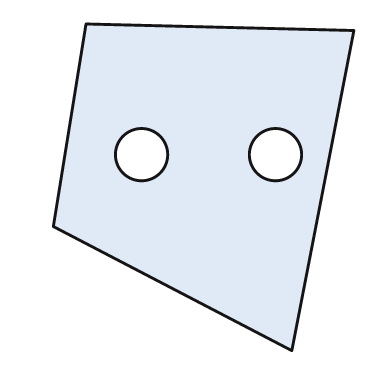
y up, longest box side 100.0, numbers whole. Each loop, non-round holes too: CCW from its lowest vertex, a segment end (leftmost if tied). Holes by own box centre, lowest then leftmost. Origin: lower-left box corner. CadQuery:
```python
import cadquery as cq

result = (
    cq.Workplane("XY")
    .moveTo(73.0, 0.0)
    .lineTo(92.0, 98.0)
    .lineTo(10.0, 100.0)
    .lineTo(0.0, 38.0)
    .close()
    .moveTo(27.0, 60.0)
    .circle(8.0)
    .moveTo(68.0, 60.0)
    .circle(8.0)
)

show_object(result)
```